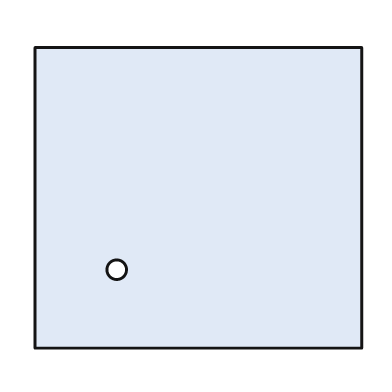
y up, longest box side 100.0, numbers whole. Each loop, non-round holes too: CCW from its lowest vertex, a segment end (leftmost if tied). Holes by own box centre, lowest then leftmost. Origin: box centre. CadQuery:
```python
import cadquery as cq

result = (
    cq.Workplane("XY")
    .moveTo(-50.0, -46.0)
    .lineTo(50.0, -46.0)
    .lineTo(50.0, 46.0)
    .lineTo(-50.0, 46.0)
    .close()
    .moveTo(-25.0, -22.0)
    .circle(3.0)
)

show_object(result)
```